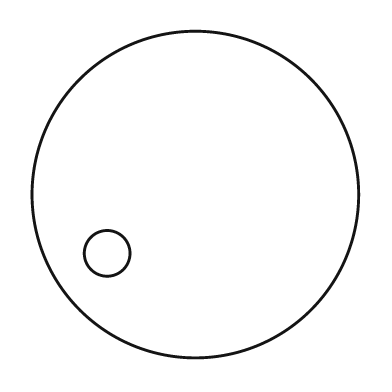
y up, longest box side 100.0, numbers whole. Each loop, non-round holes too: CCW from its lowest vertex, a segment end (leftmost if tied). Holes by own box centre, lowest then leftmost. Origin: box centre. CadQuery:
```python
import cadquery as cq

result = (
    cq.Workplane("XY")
    .moveTo(0.0, 0.0)
    .circle(50.0)
    .moveTo(-27.0, -18.0)
    .circle(7.0)
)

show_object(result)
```